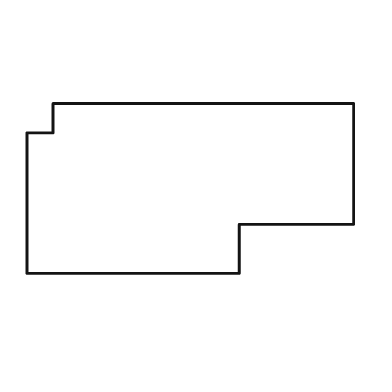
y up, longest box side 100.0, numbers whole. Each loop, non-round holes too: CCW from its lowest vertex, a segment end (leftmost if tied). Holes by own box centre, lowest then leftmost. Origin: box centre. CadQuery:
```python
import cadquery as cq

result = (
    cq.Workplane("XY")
    .moveTo(-50.0, -26.0)
    .lineTo(15.0, -26.0)
    .lineTo(15.0, -11.0)
    .lineTo(50.0, -11.0)
    .lineTo(50.0, 26.0)
    .lineTo(-42.0, 26.0)
    .lineTo(-42.0, 17.0)
    .lineTo(-50.0, 17.0)
    .close()
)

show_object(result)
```